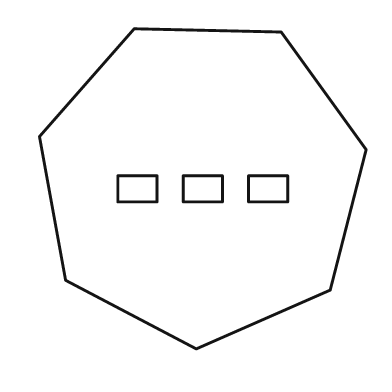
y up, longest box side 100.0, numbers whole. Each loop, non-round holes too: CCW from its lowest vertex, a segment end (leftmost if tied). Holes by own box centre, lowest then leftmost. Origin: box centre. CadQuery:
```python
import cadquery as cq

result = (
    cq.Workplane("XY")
    .moveTo(-2.0, -49.0)
    .lineTo(39.0, -31.0)
    .lineTo(50.0, 12.0)
    .lineTo(24.0, 48.0)
    .lineTo(-21.0, 49.0)
    .lineTo(-50.0, 16.0)
    .lineTo(-42.0, -28.0)
    .close()
    .moveTo(-26.0, -4.0)
    .lineTo(-14.0, -4.0)
    .lineTo(-14.0, 4.0)
    .lineTo(-26.0, 4.0)
    .close()
    .moveTo(-6.0, -4.0)
    .lineTo(6.0, -4.0)
    .lineTo(6.0, 4.0)
    .lineTo(-6.0, 4.0)
    .close()
    .moveTo(14.0, -4.0)
    .lineTo(26.0, -4.0)
    .lineTo(26.0, 4.0)
    .lineTo(14.0, 4.0)
    .close()
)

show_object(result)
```